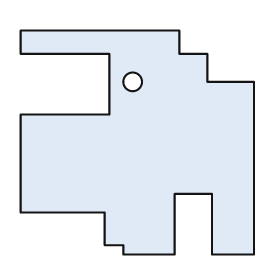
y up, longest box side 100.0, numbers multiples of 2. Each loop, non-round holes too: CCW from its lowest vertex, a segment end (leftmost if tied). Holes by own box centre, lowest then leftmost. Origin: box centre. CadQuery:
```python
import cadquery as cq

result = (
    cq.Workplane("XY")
    .moveTo(-6.0, -48.0)
    .lineTo(16.0, -48.0)
    .lineTo(16.0, -22.0)
    .lineTo(32.0, -22.0)
    .lineTo(32.0, -48.0)
    .lineTo(50.0, -48.0)
    .lineTo(50.0, 26.0)
    .lineTo(30.0, 26.0)
    .lineTo(30.0, 38.0)
    .lineTo(18.0, 38.0)
    .lineTo(18.0, 48.0)
    .lineTo(-50.0, 48.0)
    .lineTo(-50.0, 38.0)
    .lineTo(-12.0, 38.0)
    .lineTo(-12.0, 12.0)
    .lineTo(-50.0, 12.0)
    .lineTo(-50.0, -30.0)
    .lineTo(-14.0, -30.0)
    .lineTo(-14.0, -44.0)
    .lineTo(-6.0, -44.0)
    .close()
    .moveTo(-2.0, 26.0)
    .circle(4.0)
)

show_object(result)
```